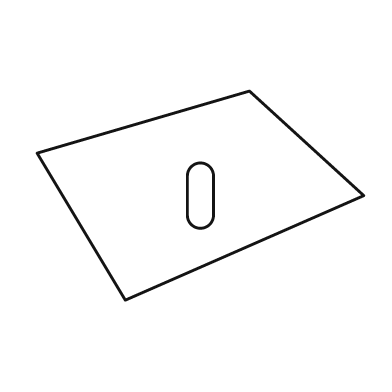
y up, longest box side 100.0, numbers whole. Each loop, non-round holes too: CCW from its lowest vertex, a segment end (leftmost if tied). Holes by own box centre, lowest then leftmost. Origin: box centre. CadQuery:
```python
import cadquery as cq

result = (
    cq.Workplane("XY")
    .moveTo(-23.0, -32.0)
    .lineTo(50.0, 0.0)
    .lineTo(15.0, 32.0)
    .lineTo(-50.0, 13.0)
    .close()
    .moveTo(-4.0, -6.0)
    .threePointArc((0.0, -10.0), (4.0, -6.0))
    .lineTo(4.0, 6.0)
    .threePointArc((0.0, 10.0), (-4.0, 6.0))
    .close()
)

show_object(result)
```